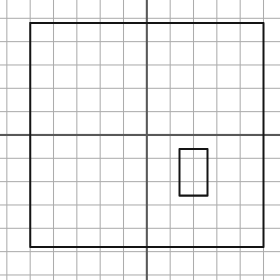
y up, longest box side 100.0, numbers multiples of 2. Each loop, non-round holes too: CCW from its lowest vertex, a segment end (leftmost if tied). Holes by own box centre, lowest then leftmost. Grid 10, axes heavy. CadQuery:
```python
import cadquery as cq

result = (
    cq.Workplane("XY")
    .moveTo(-50.0, -48.0)
    .lineTo(50.0, -48.0)
    .lineTo(50.0, 48.0)
    .lineTo(-50.0, 48.0)
    .close()
    .moveTo(14.0, -26.0)
    .lineTo(26.0, -26.0)
    .lineTo(26.0, -6.0)
    .lineTo(14.0, -6.0)
    .close()
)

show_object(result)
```